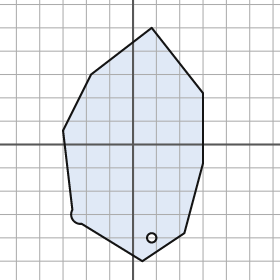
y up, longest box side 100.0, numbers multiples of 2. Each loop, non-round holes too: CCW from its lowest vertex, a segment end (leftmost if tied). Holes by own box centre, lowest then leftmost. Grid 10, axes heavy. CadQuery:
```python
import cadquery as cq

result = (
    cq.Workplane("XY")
    .moveTo(4.0, -50.0)
    .lineTo(22.0, -38.0)
    .lineTo(30.0, -8.0)
    .lineTo(30.0, 22.0)
    .lineTo(8.0, 50.0)
    .lineTo(-18.0, 30.0)
    .lineTo(-30.0, 6.0)
    .lineTo(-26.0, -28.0)
    .threePointArc((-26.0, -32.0), (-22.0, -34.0))
    .close()
    .moveTo(8.0, -40.0)
    .circle(2.0)
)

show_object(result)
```